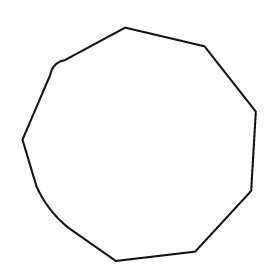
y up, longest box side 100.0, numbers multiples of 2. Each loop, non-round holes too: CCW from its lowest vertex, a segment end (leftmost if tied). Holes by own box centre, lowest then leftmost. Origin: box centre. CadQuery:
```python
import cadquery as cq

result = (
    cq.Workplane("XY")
    .moveTo(-10.0, -50.0)
    .lineTo(24.0, -46.0)
    .lineTo(48.0, -20.0)
    .lineTo(50.0, 14.0)
    .lineTo(28.0, 42.0)
    .lineTo(-6.0, 50.0)
    .lineTo(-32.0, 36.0)
    .threePointArc((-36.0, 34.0), (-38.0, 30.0))
    .lineTo(-50.0, 2.0)
    .lineTo(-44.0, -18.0)
    .threePointArc((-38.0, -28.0), (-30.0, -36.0))
    .close()
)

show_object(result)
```